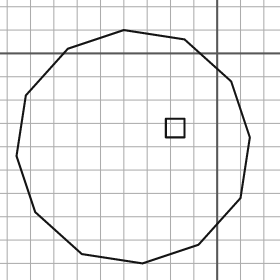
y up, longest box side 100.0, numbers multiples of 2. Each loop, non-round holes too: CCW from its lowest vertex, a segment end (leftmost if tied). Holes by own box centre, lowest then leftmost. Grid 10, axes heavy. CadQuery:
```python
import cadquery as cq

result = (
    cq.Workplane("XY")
    .moveTo(-32.0, -90.0)
    .lineTo(-8.0, -82.0)
    .lineTo(10.0, -62.0)
    .lineTo(14.0, -36.0)
    .lineTo(6.0, -12.0)
    .lineTo(-14.0, 6.0)
    .lineTo(-40.0, 10.0)
    .lineTo(-64.0, 2.0)
    .lineTo(-82.0, -18.0)
    .lineTo(-86.0, -44.0)
    .lineTo(-78.0, -68.0)
    .lineTo(-58.0, -86.0)
    .close()
    .moveTo(-22.0, -36.0)
    .lineTo(-14.0, -36.0)
    .lineTo(-14.0, -28.0)
    .lineTo(-22.0, -28.0)
    .close()
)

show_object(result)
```